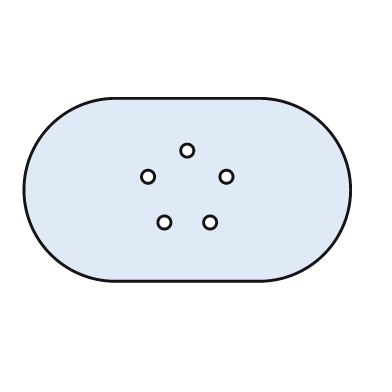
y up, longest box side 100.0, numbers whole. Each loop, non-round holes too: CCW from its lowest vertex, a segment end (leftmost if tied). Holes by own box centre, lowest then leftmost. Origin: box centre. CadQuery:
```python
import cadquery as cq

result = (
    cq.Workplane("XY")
    .moveTo(-22.0, -28.0)
    .lineTo(22.0, -28.0)
    .threePointArc((50.0, 0.0), (22.0, 28.0))
    .lineTo(-22.0, 28.0)
    .threePointArc((-50.0, 0.0), (-22.0, -28.0))
    .close()
    .moveTo(-7.0, -10.0)
    .circle(2.0)
    .moveTo(7.0, -10.0)
    .circle(2.0)
    .moveTo(-12.0, 4.0)
    .circle(2.0)
    .moveTo(12.0, 4.0)
    .circle(2.0)
    .moveTo(0.0, 12.0)
    .circle(2.0)
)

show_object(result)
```